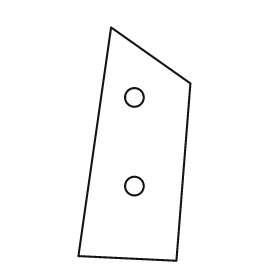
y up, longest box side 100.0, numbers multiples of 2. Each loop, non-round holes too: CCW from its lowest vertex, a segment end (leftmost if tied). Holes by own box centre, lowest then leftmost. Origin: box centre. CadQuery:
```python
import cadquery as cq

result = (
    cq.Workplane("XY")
    .moveTo(18.0, -50.0)
    .lineTo(24.0, 26.0)
    .lineTo(-10.0, 50.0)
    .lineTo(-24.0, -48.0)
    .close()
    .moveTo(0.0, -18.0)
    .circle(4.0)
    .moveTo(0.0, 20.0)
    .circle(4.0)
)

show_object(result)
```